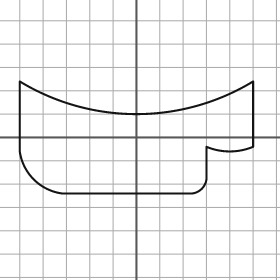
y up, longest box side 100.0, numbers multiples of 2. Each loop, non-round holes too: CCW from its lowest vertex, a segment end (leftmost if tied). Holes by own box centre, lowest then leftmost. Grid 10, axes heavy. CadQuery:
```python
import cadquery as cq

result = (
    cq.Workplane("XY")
    .moveTo(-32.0, -24.0)
    .lineTo(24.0, -24.0)
    .threePointArc((28.0, -22.0), (30.0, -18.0))
    .lineTo(30.0, -4.0)
    .threePointArc((40.0, -6.0), (50.0, -4.0))
    .lineTo(50.0, 24.0)
    .threePointArc((0.0, 10.0), (-50.0, 24.0))
    .lineTo(-50.0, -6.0)
    .threePointArc((-44.0, -18.0), (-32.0, -24.0))
    .close()
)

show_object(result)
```